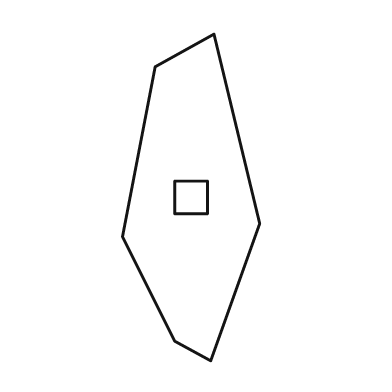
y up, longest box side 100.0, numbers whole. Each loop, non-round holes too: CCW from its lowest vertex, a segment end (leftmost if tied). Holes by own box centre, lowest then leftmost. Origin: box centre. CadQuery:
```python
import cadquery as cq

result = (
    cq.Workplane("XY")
    .moveTo(6.0, -50.0)
    .lineTo(21.0, -8.0)
    .lineTo(7.0, 50.0)
    .lineTo(-11.0, 40.0)
    .lineTo(-21.0, -12.0)
    .lineTo(-5.0, -44.0)
    .close()
    .moveTo(-5.0, -5.0)
    .lineTo(5.0, -5.0)
    .lineTo(5.0, 5.0)
    .lineTo(-5.0, 5.0)
    .close()
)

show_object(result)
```